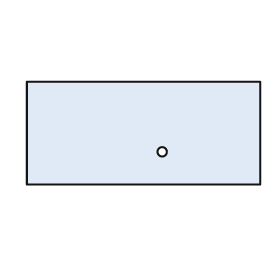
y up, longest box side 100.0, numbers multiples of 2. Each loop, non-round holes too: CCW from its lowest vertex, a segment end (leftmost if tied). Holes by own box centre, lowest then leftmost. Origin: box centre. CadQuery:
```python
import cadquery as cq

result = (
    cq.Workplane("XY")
    .moveTo(-50.0, -22.0)
    .lineTo(50.0, -22.0)
    .lineTo(50.0, 22.0)
    .lineTo(-50.0, 22.0)
    .close()
    .moveTo(8.0, -8.0)
    .circle(2.0)
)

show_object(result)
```